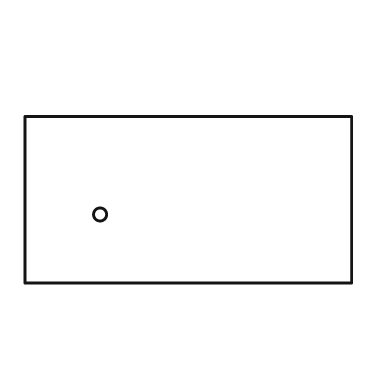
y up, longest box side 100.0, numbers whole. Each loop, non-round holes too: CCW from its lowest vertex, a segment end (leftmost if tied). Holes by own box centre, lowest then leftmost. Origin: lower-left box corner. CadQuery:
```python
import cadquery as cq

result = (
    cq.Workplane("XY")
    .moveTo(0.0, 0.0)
    .lineTo(100.0, 0.0)
    .lineTo(100.0, 51.0)
    .lineTo(0.0, 51.0)
    .close()
    .moveTo(23.0, 21.0)
    .circle(2.0)
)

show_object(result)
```